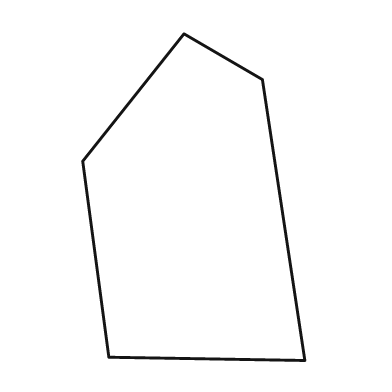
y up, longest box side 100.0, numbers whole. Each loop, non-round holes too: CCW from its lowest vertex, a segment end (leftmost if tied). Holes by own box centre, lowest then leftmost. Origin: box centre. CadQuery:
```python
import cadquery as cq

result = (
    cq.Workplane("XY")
    .moveTo(34.0, -50.0)
    .lineTo(21.0, 36.0)
    .lineTo(-3.0, 50.0)
    .lineTo(-34.0, 11.0)
    .lineTo(-26.0, -49.0)
    .close()
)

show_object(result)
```